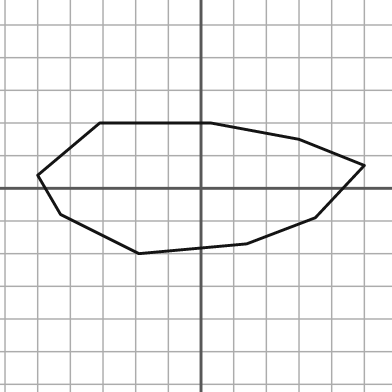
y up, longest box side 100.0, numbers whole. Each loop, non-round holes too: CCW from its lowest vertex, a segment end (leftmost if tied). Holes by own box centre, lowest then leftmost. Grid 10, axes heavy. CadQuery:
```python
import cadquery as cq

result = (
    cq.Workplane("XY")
    .moveTo(-19.0, -20.0)
    .lineTo(14.0, -17.0)
    .lineTo(35.0, -9.0)
    .lineTo(50.0, 7.0)
    .lineTo(30.0, 15.0)
    .lineTo(3.0, 20.0)
    .lineTo(-31.0, 20.0)
    .lineTo(-50.0, 4.0)
    .lineTo(-43.0, -8.0)
    .close()
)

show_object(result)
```